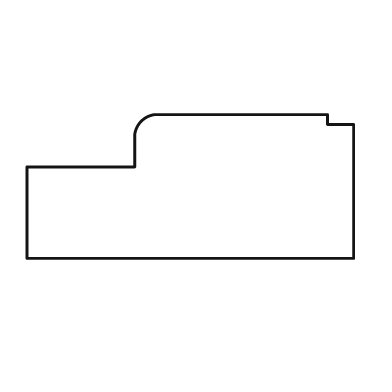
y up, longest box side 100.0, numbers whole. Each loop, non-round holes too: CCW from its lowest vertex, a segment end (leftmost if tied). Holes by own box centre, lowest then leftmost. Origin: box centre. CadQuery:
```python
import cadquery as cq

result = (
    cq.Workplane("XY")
    .moveTo(-50.0, -22.0)
    .lineTo(50.0, -22.0)
    .lineTo(50.0, 19.0)
    .lineTo(42.0, 19.0)
    .lineTo(42.0, 22.0)
    .lineTo(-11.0, 22.0)
    .threePointArc((-15.0, 20.0), (-17.0, 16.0))
    .lineTo(-17.0, 6.0)
    .lineTo(-50.0, 6.0)
    .close()
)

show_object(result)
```